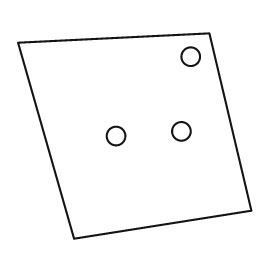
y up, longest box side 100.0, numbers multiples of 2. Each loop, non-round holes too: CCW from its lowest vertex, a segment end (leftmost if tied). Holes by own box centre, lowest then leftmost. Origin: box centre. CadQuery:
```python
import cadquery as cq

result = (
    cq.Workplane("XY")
    .moveTo(-26.0, -44.0)
    .lineTo(50.0, -32.0)
    .lineTo(32.0, 44.0)
    .lineTo(-50.0, 40.0)
    .close()
    .moveTo(-8.0, 0.0)
    .circle(4.0)
    .moveTo(20.0, 2.0)
    .circle(4.0)
    .moveTo(24.0, 34.0)
    .circle(4.0)
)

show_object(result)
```